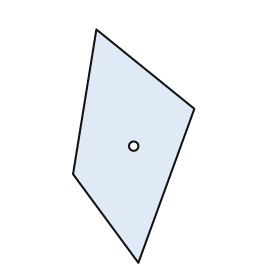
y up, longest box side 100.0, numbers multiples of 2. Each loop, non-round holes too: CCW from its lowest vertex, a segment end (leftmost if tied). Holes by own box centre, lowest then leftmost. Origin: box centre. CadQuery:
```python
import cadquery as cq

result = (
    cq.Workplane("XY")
    .moveTo(2.0, -50.0)
    .lineTo(26.0, 16.0)
    .lineTo(-16.0, 50.0)
    .lineTo(-26.0, -12.0)
    .close()
    .moveTo(0.0, 0.0)
    .circle(2.0)
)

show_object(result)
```